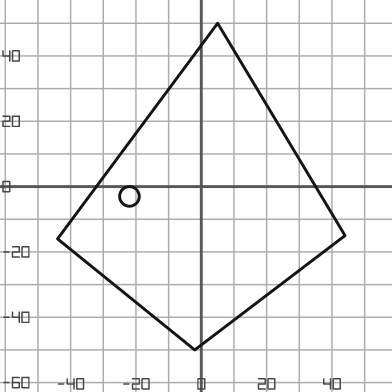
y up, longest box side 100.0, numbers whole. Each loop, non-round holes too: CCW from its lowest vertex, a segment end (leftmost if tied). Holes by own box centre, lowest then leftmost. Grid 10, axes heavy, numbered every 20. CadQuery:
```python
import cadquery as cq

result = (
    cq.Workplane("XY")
    .moveTo(-2.0, -50.0)
    .lineTo(44.0, -15.0)
    .lineTo(5.0, 50.0)
    .lineTo(-44.0, -16.0)
    .close()
    .moveTo(-22.0, -3.0)
    .circle(3.0)
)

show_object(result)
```